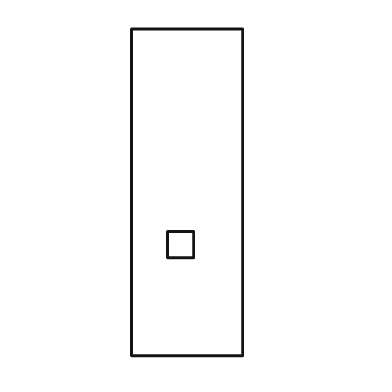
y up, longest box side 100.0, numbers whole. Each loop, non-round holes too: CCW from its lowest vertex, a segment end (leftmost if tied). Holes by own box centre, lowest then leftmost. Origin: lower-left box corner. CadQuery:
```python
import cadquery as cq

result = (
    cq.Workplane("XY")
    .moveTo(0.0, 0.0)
    .lineTo(34.0, 0.0)
    .lineTo(34.0, 100.0)
    .lineTo(0.0, 100.0)
    .close()
    .moveTo(11.0, 30.0)
    .lineTo(19.0, 30.0)
    .lineTo(19.0, 38.0)
    .lineTo(11.0, 38.0)
    .close()
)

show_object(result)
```